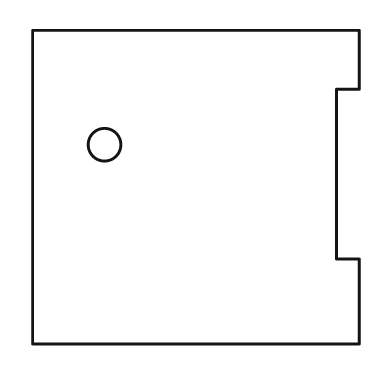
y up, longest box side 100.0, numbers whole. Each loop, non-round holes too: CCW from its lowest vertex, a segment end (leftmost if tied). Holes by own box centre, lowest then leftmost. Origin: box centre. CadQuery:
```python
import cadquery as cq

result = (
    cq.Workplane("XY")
    .moveTo(-50.0, -48.0)
    .lineTo(50.0, -48.0)
    .lineTo(50.0, -22.0)
    .lineTo(43.0, -22.0)
    .lineTo(43.0, 30.0)
    .lineTo(50.0, 30.0)
    .lineTo(50.0, 48.0)
    .lineTo(-50.0, 48.0)
    .close()
    .moveTo(-28.0, 13.0)
    .circle(5.0)
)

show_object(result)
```